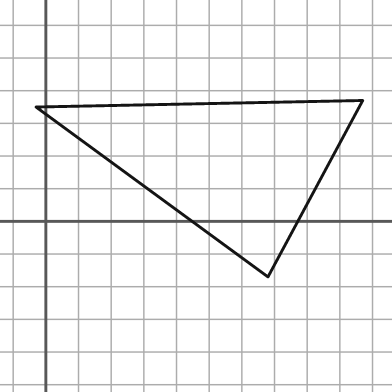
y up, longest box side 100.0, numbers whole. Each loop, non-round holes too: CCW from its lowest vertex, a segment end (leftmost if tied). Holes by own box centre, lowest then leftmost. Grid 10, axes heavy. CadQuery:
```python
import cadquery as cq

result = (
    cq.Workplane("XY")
    .moveTo(68.0, -17.0)
    .lineTo(97.0, 37.0)
    .lineTo(-3.0, 35.0)
    .close()
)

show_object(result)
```